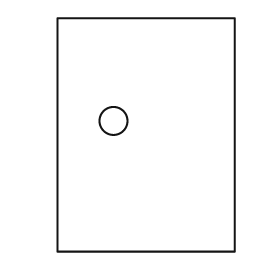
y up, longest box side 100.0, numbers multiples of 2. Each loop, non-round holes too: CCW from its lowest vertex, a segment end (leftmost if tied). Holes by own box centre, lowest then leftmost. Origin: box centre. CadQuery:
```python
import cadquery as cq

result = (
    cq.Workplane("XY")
    .moveTo(-38.0, -50.0)
    .lineTo(38.0, -50.0)
    .lineTo(38.0, 50.0)
    .lineTo(-38.0, 50.0)
    .close()
    .moveTo(-14.0, 6.0)
    .circle(6.0)
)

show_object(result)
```